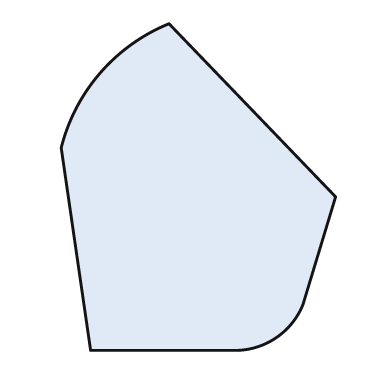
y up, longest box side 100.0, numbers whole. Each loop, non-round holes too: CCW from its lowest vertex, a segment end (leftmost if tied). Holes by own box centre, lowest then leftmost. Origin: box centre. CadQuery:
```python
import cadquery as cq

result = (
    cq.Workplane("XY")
    .moveTo(-33.0, -50.0)
    .lineTo(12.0, -50.0)
    .threePointArc((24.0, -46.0), (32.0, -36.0))
    .lineTo(42.0, -3.0)
    .lineTo(-9.0, 50.0)
    .threePointArc((-30.0, 35.0), (-42.0, 12.0))
    .close()
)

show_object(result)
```